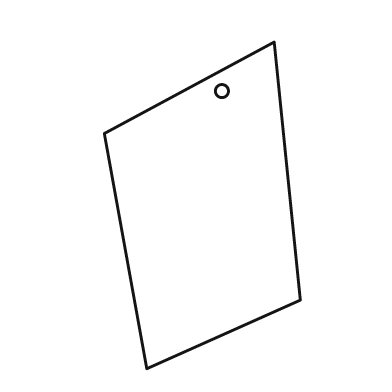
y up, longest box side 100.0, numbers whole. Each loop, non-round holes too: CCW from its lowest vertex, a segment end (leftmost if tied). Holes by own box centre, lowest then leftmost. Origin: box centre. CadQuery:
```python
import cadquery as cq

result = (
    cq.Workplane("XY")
    .moveTo(-17.0, -50.0)
    .lineTo(30.0, -29.0)
    .lineTo(22.0, 50.0)
    .lineTo(-30.0, 22.0)
    .close()
    .moveTo(6.0, 35.0)
    .circle(2.0)
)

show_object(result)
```